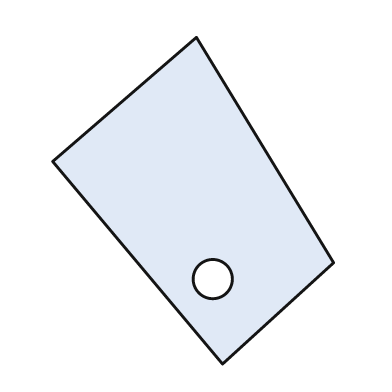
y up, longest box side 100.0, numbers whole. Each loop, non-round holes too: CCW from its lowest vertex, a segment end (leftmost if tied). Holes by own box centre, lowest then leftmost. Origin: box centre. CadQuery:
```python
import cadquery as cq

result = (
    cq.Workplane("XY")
    .moveTo(9.0, -50.0)
    .lineTo(43.0, -19.0)
    .lineTo(1.0, 50.0)
    .lineTo(-43.0, 12.0)
    .close()
    .moveTo(6.0, -24.0)
    .circle(6.0)
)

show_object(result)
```